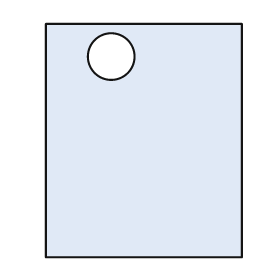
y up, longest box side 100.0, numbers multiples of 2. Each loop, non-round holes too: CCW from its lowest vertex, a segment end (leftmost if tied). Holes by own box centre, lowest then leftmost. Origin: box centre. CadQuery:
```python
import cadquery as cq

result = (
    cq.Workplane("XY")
    .moveTo(-42.0, -50.0)
    .lineTo(42.0, -50.0)
    .lineTo(42.0, 50.0)
    .lineTo(-42.0, 50.0)
    .close()
    .moveTo(-14.0, 36.0)
    .circle(10.0)
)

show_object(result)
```